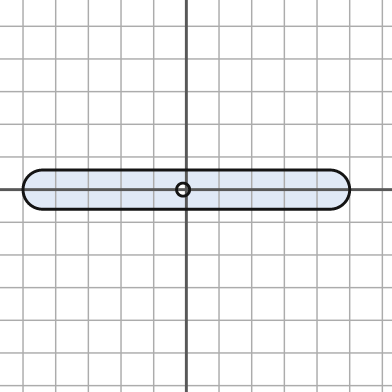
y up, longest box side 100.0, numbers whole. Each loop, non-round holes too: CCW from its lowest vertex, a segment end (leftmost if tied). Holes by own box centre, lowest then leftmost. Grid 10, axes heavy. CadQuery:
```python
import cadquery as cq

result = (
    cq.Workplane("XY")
    .moveTo(-44.0, -6.0)
    .lineTo(44.0, -6.0)
    .threePointArc((50.0, 0.0), (44.0, 6.0))
    .lineTo(-44.0, 6.0)
    .threePointArc((-50.0, 0.0), (-44.0, -6.0))
    .close()
    .moveTo(-1.0, 0.0)
    .circle(2.0)
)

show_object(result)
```